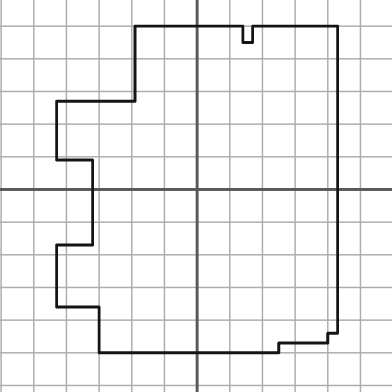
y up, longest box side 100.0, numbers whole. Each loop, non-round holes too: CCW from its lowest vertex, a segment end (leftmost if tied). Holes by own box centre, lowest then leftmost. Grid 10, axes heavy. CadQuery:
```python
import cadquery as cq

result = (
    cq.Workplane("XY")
    .moveTo(-30.0, -50.0)
    .lineTo(25.0, -50.0)
    .lineTo(25.0, -47.0)
    .lineTo(40.0, -47.0)
    .lineTo(40.0, -44.0)
    .lineTo(43.0, -44.0)
    .lineTo(43.0, 50.0)
    .lineTo(17.0, 50.0)
    .lineTo(17.0, 45.0)
    .lineTo(14.0, 45.0)
    .lineTo(14.0, 50.0)
    .lineTo(-19.0, 50.0)
    .lineTo(-19.0, 27.0)
    .lineTo(-43.0, 27.0)
    .lineTo(-43.0, 9.0)
    .lineTo(-32.0, 9.0)
    .lineTo(-32.0, -17.0)
    .lineTo(-43.0, -17.0)
    .lineTo(-43.0, -36.0)
    .lineTo(-30.0, -36.0)
    .close()
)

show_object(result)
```